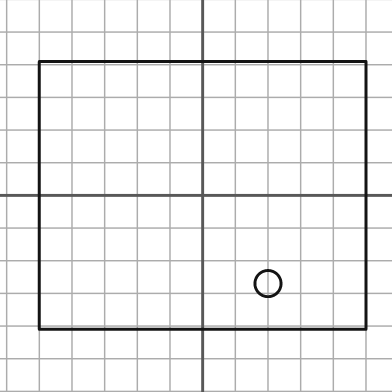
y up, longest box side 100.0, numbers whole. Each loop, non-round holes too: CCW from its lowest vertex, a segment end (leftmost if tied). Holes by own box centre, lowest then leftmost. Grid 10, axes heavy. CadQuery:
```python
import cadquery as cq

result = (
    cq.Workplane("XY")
    .moveTo(-50.0, -41.0)
    .lineTo(50.0, -41.0)
    .lineTo(50.0, 41.0)
    .lineTo(-50.0, 41.0)
    .close()
    .moveTo(20.0, -27.0)
    .circle(4.0)
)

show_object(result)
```